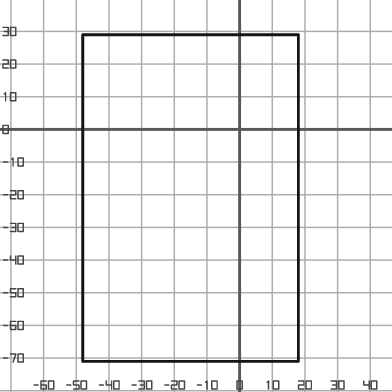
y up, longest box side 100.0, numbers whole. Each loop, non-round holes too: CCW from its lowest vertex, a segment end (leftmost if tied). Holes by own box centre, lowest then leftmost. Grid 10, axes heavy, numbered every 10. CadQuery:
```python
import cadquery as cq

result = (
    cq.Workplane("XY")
    .moveTo(-48.0, -71.0)
    .lineTo(18.0, -71.0)
    .lineTo(18.0, 29.0)
    .lineTo(-48.0, 29.0)
    .close()
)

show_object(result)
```